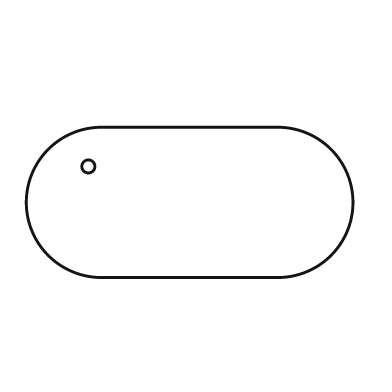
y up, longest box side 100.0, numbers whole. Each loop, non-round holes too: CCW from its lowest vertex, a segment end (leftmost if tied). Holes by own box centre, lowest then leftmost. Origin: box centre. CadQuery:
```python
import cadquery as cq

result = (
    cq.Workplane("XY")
    .moveTo(-27.0, -23.0)
    .lineTo(27.0, -23.0)
    .threePointArc((50.0, 0.0), (27.0, 23.0))
    .lineTo(-27.0, 23.0)
    .threePointArc((-50.0, 0.0), (-27.0, -23.0))
    .close()
    .moveTo(-31.0, 11.0)
    .circle(2.0)
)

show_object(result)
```